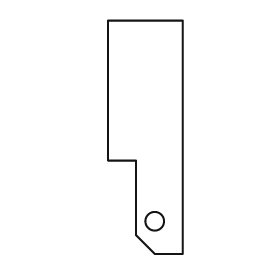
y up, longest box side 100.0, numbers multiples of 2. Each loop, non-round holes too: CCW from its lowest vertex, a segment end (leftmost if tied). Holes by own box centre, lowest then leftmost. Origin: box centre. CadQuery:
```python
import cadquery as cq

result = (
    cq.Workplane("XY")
    .moveTo(4.0, -50.0)
    .lineTo(16.0, -50.0)
    .lineTo(16.0, 50.0)
    .lineTo(-16.0, 50.0)
    .lineTo(-16.0, -10.0)
    .lineTo(-4.0, -10.0)
    .lineTo(-4.0, -42.0)
    .close()
    .moveTo(4.0, -36.0)
    .circle(4.0)
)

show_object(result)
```